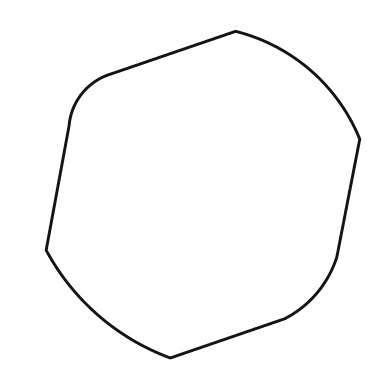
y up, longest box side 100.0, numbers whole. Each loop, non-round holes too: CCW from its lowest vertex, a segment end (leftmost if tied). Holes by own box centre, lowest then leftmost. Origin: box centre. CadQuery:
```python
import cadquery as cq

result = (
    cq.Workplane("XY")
    .moveTo(-10.0, -50.0)
    .lineTo(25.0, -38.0)
    .threePointArc((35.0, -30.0), (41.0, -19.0))
    .lineTo(48.0, 17.0)
    .threePointArc((33.0, 38.0), (10.0, 50.0))
    .lineTo(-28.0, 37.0)
    .threePointArc((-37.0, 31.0), (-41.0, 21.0))
    .lineTo(-48.0, -17.0)
    .threePointArc((-32.0, -37.0), (-10.0, -50.0))
    .close()
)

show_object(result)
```